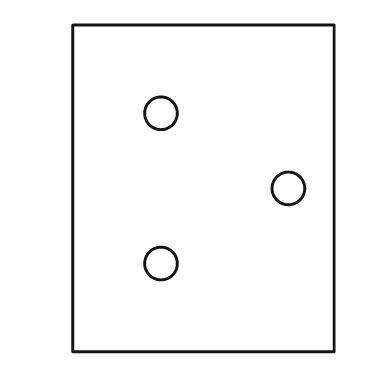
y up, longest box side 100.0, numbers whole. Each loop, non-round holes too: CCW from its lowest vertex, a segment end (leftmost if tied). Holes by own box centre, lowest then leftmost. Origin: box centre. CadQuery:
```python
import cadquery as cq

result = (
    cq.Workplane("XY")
    .moveTo(-40.0, -50.0)
    .lineTo(40.0, -50.0)
    .lineTo(40.0, 50.0)
    .lineTo(-40.0, 50.0)
    .close()
    .moveTo(-13.0, -23.0)
    .circle(5.0)
    .moveTo(26.0, 0.0)
    .circle(5.0)
    .moveTo(-13.0, 23.0)
    .circle(5.0)
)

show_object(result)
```